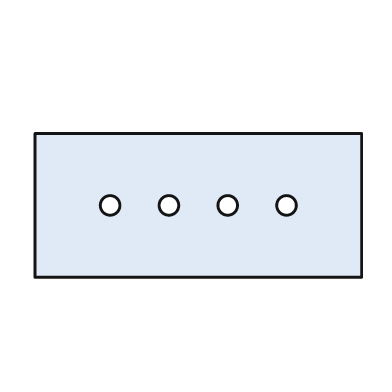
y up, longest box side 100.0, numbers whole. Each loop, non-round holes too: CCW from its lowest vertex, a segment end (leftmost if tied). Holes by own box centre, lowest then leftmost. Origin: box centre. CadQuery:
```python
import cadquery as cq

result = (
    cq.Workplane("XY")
    .moveTo(-50.0, -22.0)
    .lineTo(50.0, -22.0)
    .lineTo(50.0, 22.0)
    .lineTo(-50.0, 22.0)
    .close()
    .moveTo(-27.0, 0.0)
    .circle(3.0)
    .moveTo(-9.0, 0.0)
    .circle(3.0)
    .moveTo(9.0, 0.0)
    .circle(3.0)
    .moveTo(27.0, 0.0)
    .circle(3.0)
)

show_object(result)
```